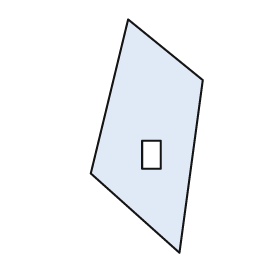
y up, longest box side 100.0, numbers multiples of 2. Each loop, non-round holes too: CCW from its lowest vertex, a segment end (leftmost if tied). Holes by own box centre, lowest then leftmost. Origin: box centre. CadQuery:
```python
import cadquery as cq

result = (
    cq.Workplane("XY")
    .moveTo(14.0, -50.0)
    .lineTo(24.0, 24.0)
    .lineTo(-8.0, 50.0)
    .lineTo(-24.0, -16.0)
    .close()
    .moveTo(-2.0, -14.0)
    .lineTo(6.0, -14.0)
    .lineTo(6.0, -2.0)
    .lineTo(-2.0, -2.0)
    .close()
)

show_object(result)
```